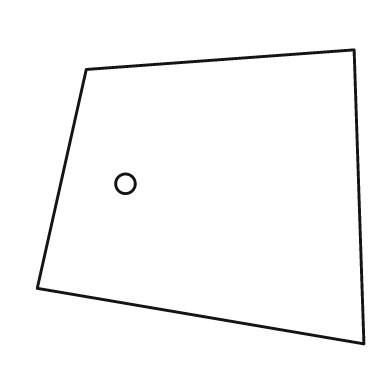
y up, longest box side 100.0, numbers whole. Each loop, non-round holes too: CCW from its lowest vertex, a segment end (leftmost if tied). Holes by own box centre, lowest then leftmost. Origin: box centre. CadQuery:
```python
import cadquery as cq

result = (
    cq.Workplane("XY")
    .moveTo(50.0, -45.0)
    .lineTo(47.0, 45.0)
    .lineTo(-35.0, 39.0)
    .lineTo(-50.0, -28.0)
    .close()
    .moveTo(-23.0, 4.0)
    .circle(3.0)
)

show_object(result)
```